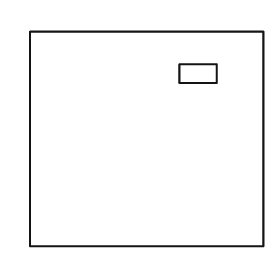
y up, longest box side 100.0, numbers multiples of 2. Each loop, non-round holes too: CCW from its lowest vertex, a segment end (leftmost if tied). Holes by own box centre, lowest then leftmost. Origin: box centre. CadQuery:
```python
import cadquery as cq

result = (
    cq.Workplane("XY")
    .moveTo(-50.0, -46.0)
    .lineTo(50.0, -46.0)
    .lineTo(50.0, 46.0)
    .lineTo(-50.0, 46.0)
    .close()
    .moveTo(14.0, 24.0)
    .lineTo(30.0, 24.0)
    .lineTo(30.0, 32.0)
    .lineTo(14.0, 32.0)
    .close()
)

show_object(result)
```